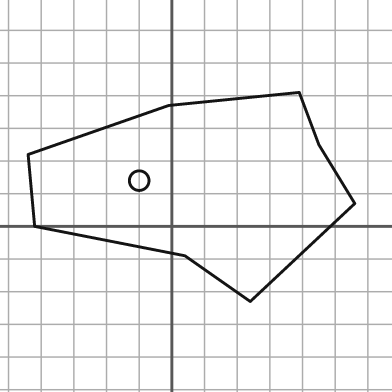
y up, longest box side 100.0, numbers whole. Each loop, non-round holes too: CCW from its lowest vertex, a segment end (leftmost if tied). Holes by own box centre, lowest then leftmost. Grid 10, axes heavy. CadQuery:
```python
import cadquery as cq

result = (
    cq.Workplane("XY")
    .moveTo(24.0, -23.0)
    .lineTo(56.0, 7.0)
    .lineTo(45.0, 25.0)
    .lineTo(39.0, 41.0)
    .lineTo(-1.0, 37.0)
    .lineTo(-44.0, 22.0)
    .lineTo(-42.0, 0.0)
    .lineTo(4.0, -9.0)
    .close()
    .moveTo(-10.0, 14.0)
    .circle(3.0)
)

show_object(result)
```